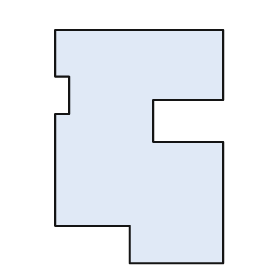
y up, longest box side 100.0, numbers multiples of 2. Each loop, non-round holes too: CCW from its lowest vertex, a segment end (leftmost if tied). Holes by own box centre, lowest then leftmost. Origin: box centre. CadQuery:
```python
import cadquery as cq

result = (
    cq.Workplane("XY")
    .moveTo(-4.0, -50.0)
    .lineTo(36.0, -50.0)
    .lineTo(36.0, 2.0)
    .lineTo(6.0, 2.0)
    .lineTo(6.0, 20.0)
    .lineTo(36.0, 20.0)
    .lineTo(36.0, 50.0)
    .lineTo(-36.0, 50.0)
    .lineTo(-36.0, 30.0)
    .lineTo(-30.0, 30.0)
    .lineTo(-30.0, 14.0)
    .lineTo(-36.0, 14.0)
    .lineTo(-36.0, -34.0)
    .lineTo(-4.0, -34.0)
    .close()
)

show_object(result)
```